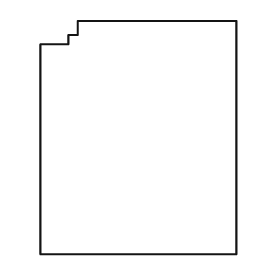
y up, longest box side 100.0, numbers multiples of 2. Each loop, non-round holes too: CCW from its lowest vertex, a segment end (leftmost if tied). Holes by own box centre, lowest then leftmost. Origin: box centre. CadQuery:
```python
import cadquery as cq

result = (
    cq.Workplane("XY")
    .moveTo(-42.0, -50.0)
    .lineTo(42.0, -50.0)
    .lineTo(42.0, 50.0)
    .lineTo(-26.0, 50.0)
    .lineTo(-26.0, 44.0)
    .lineTo(-30.0, 44.0)
    .lineTo(-30.0, 40.0)
    .lineTo(-42.0, 40.0)
    .close()
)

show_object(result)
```